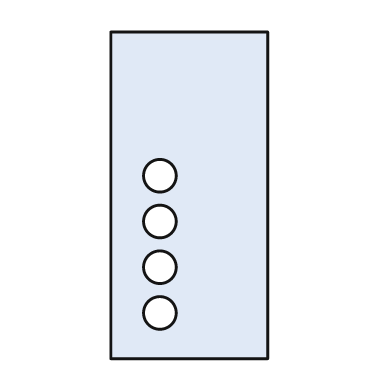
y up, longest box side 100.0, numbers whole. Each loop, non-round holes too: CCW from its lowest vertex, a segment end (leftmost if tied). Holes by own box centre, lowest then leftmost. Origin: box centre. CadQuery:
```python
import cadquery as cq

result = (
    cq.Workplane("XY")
    .moveTo(-24.0, -50.0)
    .lineTo(24.0, -50.0)
    .lineTo(24.0, 50.0)
    .lineTo(-24.0, 50.0)
    .close()
    .moveTo(-9.0, -36.0)
    .circle(5.0)
    .moveTo(-9.0, -22.0)
    .circle(5.0)
    .moveTo(-9.0, -8.0)
    .circle(5.0)
    .moveTo(-9.0, 6.0)
    .circle(5.0)
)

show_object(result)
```